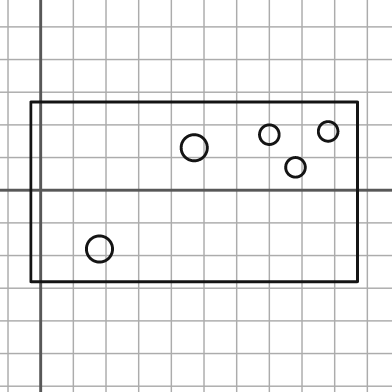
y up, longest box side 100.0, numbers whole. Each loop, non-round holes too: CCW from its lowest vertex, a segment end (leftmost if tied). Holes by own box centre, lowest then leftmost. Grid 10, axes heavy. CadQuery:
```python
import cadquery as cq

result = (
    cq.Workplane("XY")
    .moveTo(-3.0, -28.0)
    .lineTo(97.0, -28.0)
    .lineTo(97.0, 27.0)
    .lineTo(-3.0, 27.0)
    .close()
    .moveTo(18.0, -18.0)
    .circle(4.0)
    .moveTo(78.0, 7.0)
    .circle(3.0)
    .moveTo(47.0, 13.0)
    .circle(4.0)
    .moveTo(70.0, 17.0)
    .circle(3.0)
    .moveTo(88.0, 18.0)
    .circle(3.0)
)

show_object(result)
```